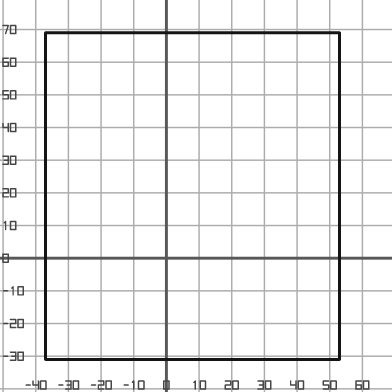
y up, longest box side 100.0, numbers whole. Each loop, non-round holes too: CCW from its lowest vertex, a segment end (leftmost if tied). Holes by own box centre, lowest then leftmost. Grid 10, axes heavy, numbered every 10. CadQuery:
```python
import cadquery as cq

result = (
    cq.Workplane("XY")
    .moveTo(-37.0, -31.0)
    .lineTo(53.0, -31.0)
    .lineTo(53.0, 69.0)
    .lineTo(-37.0, 69.0)
    .close()
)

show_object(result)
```